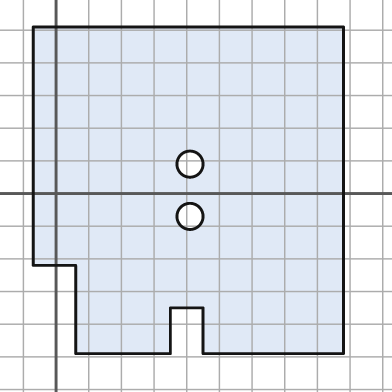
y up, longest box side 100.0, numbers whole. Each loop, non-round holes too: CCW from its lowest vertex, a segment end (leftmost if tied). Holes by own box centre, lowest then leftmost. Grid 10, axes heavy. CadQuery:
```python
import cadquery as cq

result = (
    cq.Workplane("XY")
    .moveTo(6.0, -49.0)
    .lineTo(35.0, -49.0)
    .lineTo(35.0, -35.0)
    .lineTo(45.0, -35.0)
    .lineTo(45.0, -49.0)
    .lineTo(88.0, -49.0)
    .lineTo(88.0, 51.0)
    .lineTo(-7.0, 51.0)
    .lineTo(-7.0, -22.0)
    .lineTo(6.0, -22.0)
    .close()
    .moveTo(41.0, -7.0)
    .circle(4.0)
    .moveTo(41.0, 9.0)
    .circle(4.0)
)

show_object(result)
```